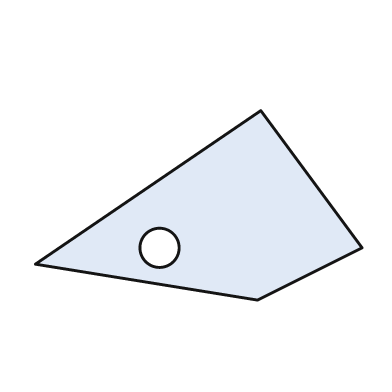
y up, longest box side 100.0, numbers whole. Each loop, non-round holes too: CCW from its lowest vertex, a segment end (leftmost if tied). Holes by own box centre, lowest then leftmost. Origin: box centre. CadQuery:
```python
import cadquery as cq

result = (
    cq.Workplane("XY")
    .moveTo(18.0, -29.0)
    .lineTo(50.0, -13.0)
    .lineTo(19.0, 29.0)
    .lineTo(-50.0, -18.0)
    .close()
    .moveTo(-12.0, -13.0)
    .circle(6.0)
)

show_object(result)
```